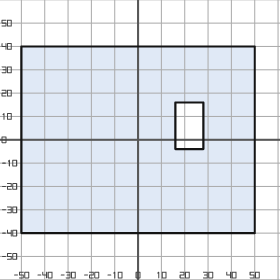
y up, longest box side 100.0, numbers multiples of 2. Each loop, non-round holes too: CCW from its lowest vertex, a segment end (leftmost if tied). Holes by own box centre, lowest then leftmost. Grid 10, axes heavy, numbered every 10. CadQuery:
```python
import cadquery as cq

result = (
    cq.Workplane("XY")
    .moveTo(-50.0, -40.0)
    .lineTo(50.0, -40.0)
    .lineTo(50.0, 40.0)
    .lineTo(-50.0, 40.0)
    .close()
    .moveTo(16.0, -4.0)
    .lineTo(28.0, -4.0)
    .lineTo(28.0, 16.0)
    .lineTo(16.0, 16.0)
    .close()
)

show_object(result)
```